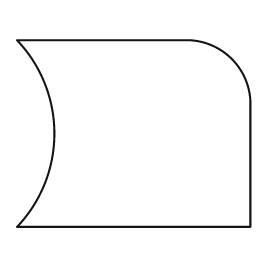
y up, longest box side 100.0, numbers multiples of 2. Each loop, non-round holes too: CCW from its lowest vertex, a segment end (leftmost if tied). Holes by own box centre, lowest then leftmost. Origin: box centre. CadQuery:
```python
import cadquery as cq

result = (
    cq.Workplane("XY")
    .moveTo(-50.0, -40.0)
    .lineTo(50.0, -40.0)
    .lineTo(50.0, 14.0)
    .threePointArc((42.0, 32.0), (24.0, 40.0))
    .lineTo(-50.0, 40.0)
    .threePointArc((-34.0, 0.0), (-50.0, -40.0))
    .close()
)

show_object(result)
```